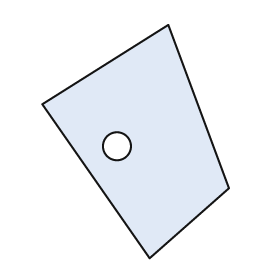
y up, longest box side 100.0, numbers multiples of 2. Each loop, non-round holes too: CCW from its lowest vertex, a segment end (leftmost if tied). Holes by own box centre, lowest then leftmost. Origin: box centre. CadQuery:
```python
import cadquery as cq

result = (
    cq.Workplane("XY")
    .moveTo(6.0, -50.0)
    .lineTo(40.0, -20.0)
    .lineTo(14.0, 50.0)
    .lineTo(-40.0, 16.0)
    .close()
    .moveTo(-8.0, -2.0)
    .circle(6.0)
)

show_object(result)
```